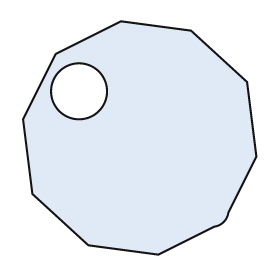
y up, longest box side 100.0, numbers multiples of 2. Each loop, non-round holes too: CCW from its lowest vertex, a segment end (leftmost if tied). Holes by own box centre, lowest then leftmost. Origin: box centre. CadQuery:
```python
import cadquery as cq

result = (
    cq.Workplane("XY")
    .moveTo(8.0, -50.0)
    .lineTo(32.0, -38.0)
    .threePointArc((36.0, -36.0), (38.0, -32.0))
    .lineTo(50.0, -8.0)
    .lineTo(46.0, 24.0)
    .lineTo(22.0, 46.0)
    .lineTo(-8.0, 50.0)
    .lineTo(-36.0, 36.0)
    .lineTo(-50.0, 8.0)
    .lineTo(-46.0, -24.0)
    .lineTo(-22.0, -46.0)
    .close()
    .moveTo(-26.0, 20.0)
    .circle(12.0)
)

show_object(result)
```